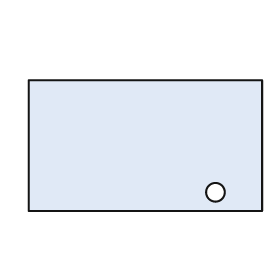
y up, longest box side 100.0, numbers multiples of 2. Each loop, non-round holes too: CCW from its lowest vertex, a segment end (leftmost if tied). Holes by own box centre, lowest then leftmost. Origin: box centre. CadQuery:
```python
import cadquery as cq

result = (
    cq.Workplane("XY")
    .moveTo(-50.0, -28.0)
    .lineTo(50.0, -28.0)
    .lineTo(50.0, 28.0)
    .lineTo(-50.0, 28.0)
    .close()
    .moveTo(30.0, -20.0)
    .circle(4.0)
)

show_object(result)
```